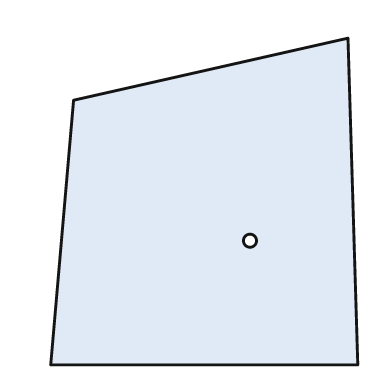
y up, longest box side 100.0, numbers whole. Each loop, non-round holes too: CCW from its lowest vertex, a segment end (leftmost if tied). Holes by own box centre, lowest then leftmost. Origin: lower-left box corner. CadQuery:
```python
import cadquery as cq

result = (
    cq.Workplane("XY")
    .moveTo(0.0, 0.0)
    .lineTo(94.0, 0.0)
    .lineTo(91.0, 100.0)
    .lineTo(7.0, 81.0)
    .close()
    .moveTo(61.0, 38.0)
    .circle(2.0)
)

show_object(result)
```